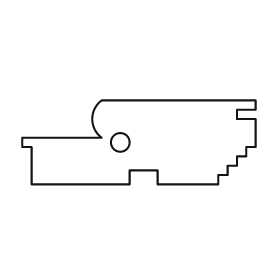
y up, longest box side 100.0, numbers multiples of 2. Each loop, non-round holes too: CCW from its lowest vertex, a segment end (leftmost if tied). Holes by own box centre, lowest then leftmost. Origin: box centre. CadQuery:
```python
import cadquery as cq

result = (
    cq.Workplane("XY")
    .moveTo(-46.0, -18.0)
    .lineTo(-4.0, -18.0)
    .lineTo(-4.0, -12.0)
    .lineTo(8.0, -12.0)
    .lineTo(8.0, -18.0)
    .lineTo(34.0, -18.0)
    .lineTo(34.0, -14.0)
    .lineTo(38.0, -14.0)
    .lineTo(38.0, -10.0)
    .lineTo(42.0, -10.0)
    .lineTo(42.0, -6.0)
    .lineTo(46.0, -6.0)
    .lineTo(46.0, -2.0)
    .lineTo(50.0, -2.0)
    .lineTo(50.0, 10.0)
    .lineTo(42.0, 10.0)
    .lineTo(42.0, 14.0)
    .lineTo(50.0, 14.0)
    .lineTo(50.0, 18.0)
    .lineTo(-16.0, 18.0)
    .threePointArc((-20.0, 10.0), (-16.0, 2.0))
    .lineTo(-50.0, 2.0)
    .lineTo(-50.0, -2.0)
    .lineTo(-46.0, -2.0)
    .close()
    .moveTo(-8.0, 0.0)
    .circle(4.0)
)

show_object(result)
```